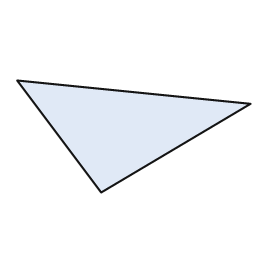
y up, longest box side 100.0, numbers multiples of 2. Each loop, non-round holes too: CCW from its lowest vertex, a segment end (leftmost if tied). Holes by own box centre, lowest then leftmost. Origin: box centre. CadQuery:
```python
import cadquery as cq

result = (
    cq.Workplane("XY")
    .moveTo(-14.0, -24.0)
    .lineTo(50.0, 14.0)
    .lineTo(-50.0, 24.0)
    .close()
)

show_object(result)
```